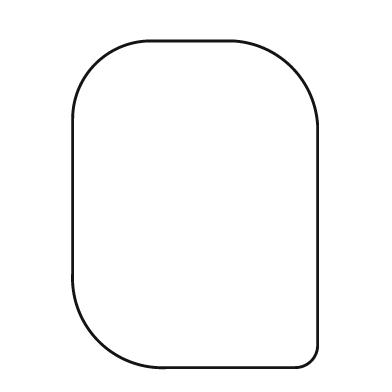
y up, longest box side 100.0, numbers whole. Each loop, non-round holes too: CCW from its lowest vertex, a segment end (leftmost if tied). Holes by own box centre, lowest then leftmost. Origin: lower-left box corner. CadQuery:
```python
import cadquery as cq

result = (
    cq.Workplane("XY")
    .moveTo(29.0, 0.0)
    .lineTo(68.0, 0.0)
    .threePointArc((73.0, 2.0), (75.0, 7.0))
    .lineTo(75.0, 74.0)
    .threePointArc((67.0, 92.0), (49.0, 100.0))
    .lineTo(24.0, 100.0)
    .threePointArc((7.0, 93.0), (0.0, 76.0))
    .lineTo(0.0, 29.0)
    .threePointArc((8.0, 8.0), (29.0, 0.0))
    .close()
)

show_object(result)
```